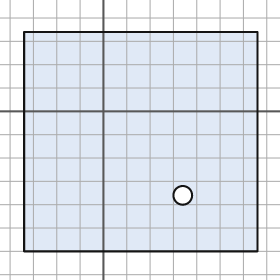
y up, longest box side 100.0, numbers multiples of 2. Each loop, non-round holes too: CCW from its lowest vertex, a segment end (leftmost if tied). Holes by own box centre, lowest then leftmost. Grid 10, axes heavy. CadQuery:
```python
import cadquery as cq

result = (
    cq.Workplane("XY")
    .moveTo(-34.0, -60.0)
    .lineTo(66.0, -60.0)
    .lineTo(66.0, 34.0)
    .lineTo(-34.0, 34.0)
    .close()
    .moveTo(34.0, -36.0)
    .circle(4.0)
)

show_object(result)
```